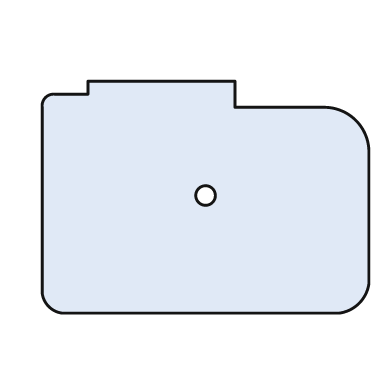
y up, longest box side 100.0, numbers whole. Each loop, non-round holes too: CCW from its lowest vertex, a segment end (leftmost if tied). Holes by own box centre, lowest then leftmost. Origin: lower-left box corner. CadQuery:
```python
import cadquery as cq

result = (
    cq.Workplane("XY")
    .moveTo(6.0, 0.0)
    .lineTo(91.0, 0.0)
    .threePointArc((97.0, 3.0), (100.0, 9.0))
    .lineTo(100.0, 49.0)
    .threePointArc((96.0, 59.0), (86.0, 63.0))
    .lineTo(59.0, 63.0)
    .lineTo(59.0, 71.0)
    .lineTo(14.0, 71.0)
    .lineTo(14.0, 67.0)
    .lineTo(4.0, 67.0)
    .threePointArc((1.0, 66.0), (0.0, 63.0))
    .lineTo(0.0, 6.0)
    .threePointArc((2.0, 2.0), (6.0, 0.0))
    .close()
    .moveTo(50.0, 36.0)
    .circle(3.0)
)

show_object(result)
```